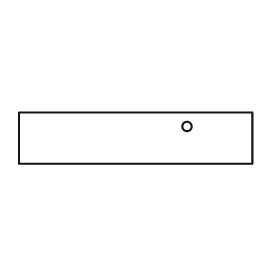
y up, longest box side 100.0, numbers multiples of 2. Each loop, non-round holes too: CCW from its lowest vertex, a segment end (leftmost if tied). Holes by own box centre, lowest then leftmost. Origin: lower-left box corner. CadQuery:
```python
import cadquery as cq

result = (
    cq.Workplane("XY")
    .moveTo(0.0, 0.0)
    .lineTo(100.0, 0.0)
    .lineTo(100.0, 22.0)
    .lineTo(0.0, 22.0)
    .close()
    .moveTo(72.0, 16.0)
    .circle(2.0)
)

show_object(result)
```